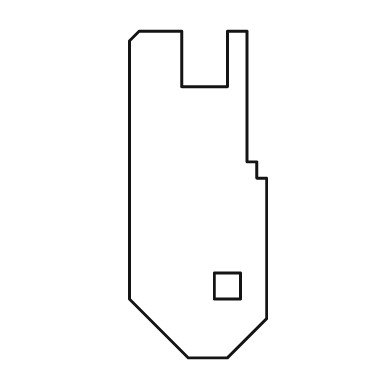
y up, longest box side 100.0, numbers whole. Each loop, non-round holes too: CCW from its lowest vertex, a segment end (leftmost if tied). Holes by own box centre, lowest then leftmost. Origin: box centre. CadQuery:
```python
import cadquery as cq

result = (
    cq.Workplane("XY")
    .moveTo(-3.0, -50.0)
    .lineTo(9.0, -50.0)
    .lineTo(21.0, -38.0)
    .lineTo(21.0, 5.0)
    .lineTo(18.0, 5.0)
    .lineTo(18.0, 10.0)
    .lineTo(15.0, 10.0)
    .lineTo(15.0, 50.0)
    .lineTo(9.0, 50.0)
    .lineTo(9.0, 33.0)
    .lineTo(-5.0, 33.0)
    .lineTo(-5.0, 50.0)
    .lineTo(-18.0, 50.0)
    .lineTo(-21.0, 47.0)
    .lineTo(-21.0, -32.0)
    .close()
    .moveTo(5.0, -32.0)
    .lineTo(13.0, -32.0)
    .lineTo(13.0, -24.0)
    .lineTo(5.0, -24.0)
    .close()
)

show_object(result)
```